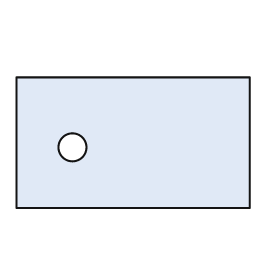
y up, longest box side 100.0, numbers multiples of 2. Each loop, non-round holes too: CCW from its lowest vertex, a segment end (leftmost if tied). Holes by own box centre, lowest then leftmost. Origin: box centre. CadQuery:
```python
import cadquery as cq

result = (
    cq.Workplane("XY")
    .moveTo(-50.0, -28.0)
    .lineTo(50.0, -28.0)
    .lineTo(50.0, 28.0)
    .lineTo(-50.0, 28.0)
    .close()
    .moveTo(-26.0, -2.0)
    .circle(6.0)
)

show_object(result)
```